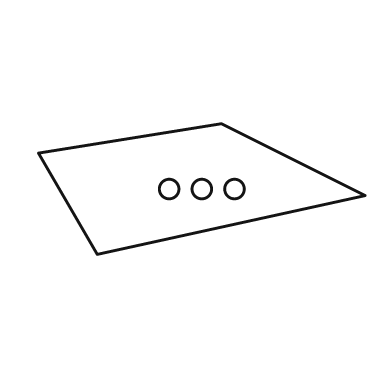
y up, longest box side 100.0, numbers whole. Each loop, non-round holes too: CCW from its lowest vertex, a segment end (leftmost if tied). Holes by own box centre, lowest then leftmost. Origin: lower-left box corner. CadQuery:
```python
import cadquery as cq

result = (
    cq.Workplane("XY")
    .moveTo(18.0, 0.0)
    .lineTo(100.0, 18.0)
    .lineTo(56.0, 40.0)
    .lineTo(0.0, 31.0)
    .close()
    .moveTo(40.0, 20.0)
    .circle(3.0)
    .moveTo(50.0, 20.0)
    .circle(3.0)
    .moveTo(60.0, 20.0)
    .circle(3.0)
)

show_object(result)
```